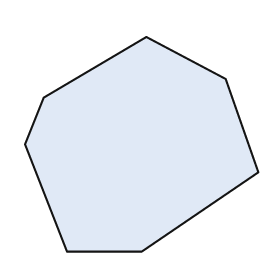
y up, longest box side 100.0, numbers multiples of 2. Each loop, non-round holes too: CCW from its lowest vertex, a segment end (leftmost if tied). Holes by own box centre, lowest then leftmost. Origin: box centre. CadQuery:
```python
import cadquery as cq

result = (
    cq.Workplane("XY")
    .moveTo(-32.0, -46.0)
    .lineTo(0.0, -46.0)
    .lineTo(50.0, -12.0)
    .lineTo(36.0, 28.0)
    .lineTo(2.0, 46.0)
    .lineTo(-42.0, 20.0)
    .lineTo(-50.0, 0.0)
    .close()
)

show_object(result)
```